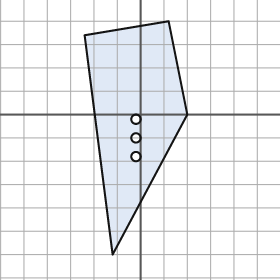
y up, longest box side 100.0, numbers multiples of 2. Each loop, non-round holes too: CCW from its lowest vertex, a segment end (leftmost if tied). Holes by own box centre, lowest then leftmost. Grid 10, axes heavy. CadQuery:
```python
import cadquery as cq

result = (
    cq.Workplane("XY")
    .moveTo(-12.0, -60.0)
    .lineTo(20.0, 0.0)
    .lineTo(12.0, 40.0)
    .lineTo(-24.0, 34.0)
    .close()
    .moveTo(-2.0, -18.0)
    .circle(2.0)
    .moveTo(-2.0, -10.0)
    .circle(2.0)
    .moveTo(-2.0, -2.0)
    .circle(2.0)
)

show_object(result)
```